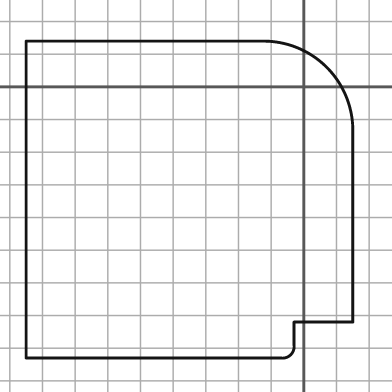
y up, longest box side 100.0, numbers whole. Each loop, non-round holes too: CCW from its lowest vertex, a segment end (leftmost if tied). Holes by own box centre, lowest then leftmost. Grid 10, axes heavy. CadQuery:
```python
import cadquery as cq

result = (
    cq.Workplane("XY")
    .moveTo(-85.0, -83.0)
    .lineTo(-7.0, -83.0)
    .threePointArc((-4.0, -82.0), (-3.0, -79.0))
    .lineTo(-3.0, -72.0)
    .lineTo(15.0, -72.0)
    .lineTo(15.0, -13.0)
    .threePointArc((7.0, 6.0), (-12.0, 14.0))
    .lineTo(-85.0, 14.0)
    .close()
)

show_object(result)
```